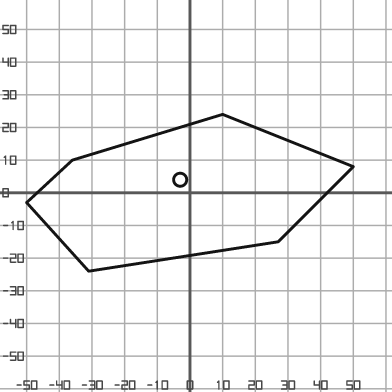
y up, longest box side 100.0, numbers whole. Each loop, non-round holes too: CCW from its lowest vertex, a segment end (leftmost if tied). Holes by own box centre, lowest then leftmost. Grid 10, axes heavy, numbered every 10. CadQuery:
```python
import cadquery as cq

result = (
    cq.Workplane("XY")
    .moveTo(-31.0, -24.0)
    .lineTo(27.0, -15.0)
    .lineTo(50.0, 8.0)
    .lineTo(10.0, 24.0)
    .lineTo(-36.0, 10.0)
    .lineTo(-50.0, -3.0)
    .close()
    .moveTo(-3.0, 4.0)
    .circle(2.0)
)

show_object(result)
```